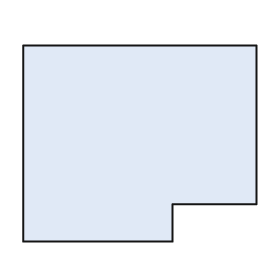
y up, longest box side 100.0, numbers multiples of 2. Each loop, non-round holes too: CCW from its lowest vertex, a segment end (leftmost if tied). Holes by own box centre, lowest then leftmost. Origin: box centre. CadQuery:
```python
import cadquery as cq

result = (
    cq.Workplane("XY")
    .moveTo(-50.0, -42.0)
    .lineTo(14.0, -42.0)
    .lineTo(14.0, -26.0)
    .lineTo(50.0, -26.0)
    .lineTo(50.0, 42.0)
    .lineTo(-50.0, 42.0)
    .close()
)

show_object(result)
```